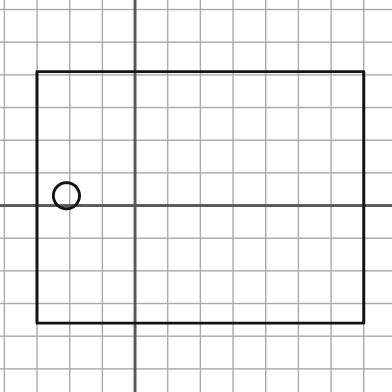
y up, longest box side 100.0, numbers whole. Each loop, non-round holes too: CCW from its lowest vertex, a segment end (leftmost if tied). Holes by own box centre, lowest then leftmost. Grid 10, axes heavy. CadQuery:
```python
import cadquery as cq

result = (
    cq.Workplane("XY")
    .moveTo(-30.0, -36.0)
    .lineTo(70.0, -36.0)
    .lineTo(70.0, 41.0)
    .lineTo(-30.0, 41.0)
    .close()
    .moveTo(-21.0, 3.0)
    .circle(4.0)
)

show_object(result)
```